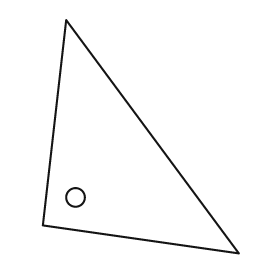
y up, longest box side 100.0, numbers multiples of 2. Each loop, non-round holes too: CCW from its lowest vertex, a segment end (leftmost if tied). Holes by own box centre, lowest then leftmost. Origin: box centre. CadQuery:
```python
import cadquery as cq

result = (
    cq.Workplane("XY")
    .moveTo(42.0, -50.0)
    .lineTo(-32.0, 50.0)
    .lineTo(-42.0, -38.0)
    .close()
    .moveTo(-28.0, -26.0)
    .circle(4.0)
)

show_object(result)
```